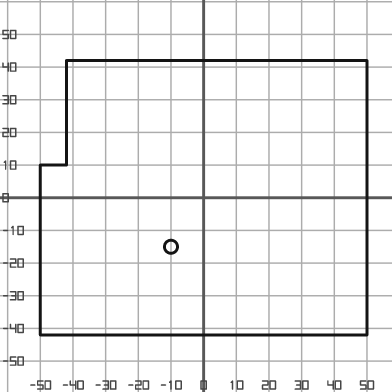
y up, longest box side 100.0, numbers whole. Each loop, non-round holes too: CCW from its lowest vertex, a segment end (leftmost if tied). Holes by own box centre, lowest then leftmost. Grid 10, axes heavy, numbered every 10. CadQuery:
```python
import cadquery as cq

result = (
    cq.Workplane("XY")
    .moveTo(-50.0, -42.0)
    .lineTo(50.0, -42.0)
    .lineTo(50.0, 42.0)
    .lineTo(-42.0, 42.0)
    .lineTo(-42.0, 10.0)
    .lineTo(-50.0, 10.0)
    .close()
    .moveTo(-10.0, -15.0)
    .circle(2.0)
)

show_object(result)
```